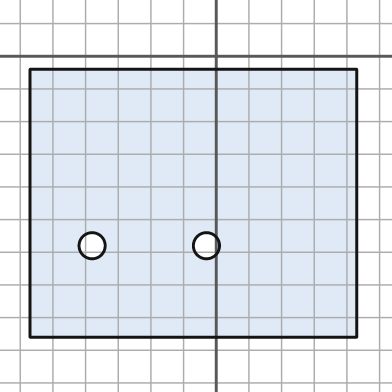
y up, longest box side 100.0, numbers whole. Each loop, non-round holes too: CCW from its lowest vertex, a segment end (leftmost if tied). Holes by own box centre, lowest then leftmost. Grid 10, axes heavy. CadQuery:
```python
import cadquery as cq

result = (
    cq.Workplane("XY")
    .moveTo(-57.0, -86.0)
    .lineTo(43.0, -86.0)
    .lineTo(43.0, -4.0)
    .lineTo(-57.0, -4.0)
    .close()
    .moveTo(-38.0, -58.0)
    .circle(4.0)
    .moveTo(-3.0, -58.0)
    .circle(4.0)
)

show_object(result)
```